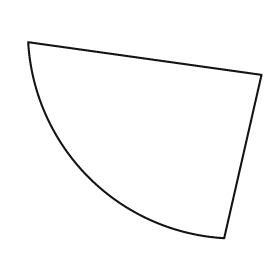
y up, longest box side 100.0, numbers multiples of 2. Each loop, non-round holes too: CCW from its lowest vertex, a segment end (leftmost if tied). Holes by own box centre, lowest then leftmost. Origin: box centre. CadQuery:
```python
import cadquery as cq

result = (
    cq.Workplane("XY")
    .moveTo(34.0, -42.0)
    .lineTo(50.0, 28.0)
    .lineTo(-50.0, 42.0)
    .threePointArc((-24.0, -16.0), (34.0, -42.0))
    .close()
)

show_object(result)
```